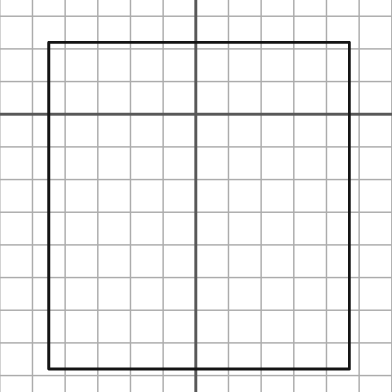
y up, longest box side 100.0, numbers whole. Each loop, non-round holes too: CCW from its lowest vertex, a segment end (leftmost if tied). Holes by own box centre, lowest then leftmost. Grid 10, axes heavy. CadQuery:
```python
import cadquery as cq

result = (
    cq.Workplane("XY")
    .moveTo(-45.0, -78.0)
    .lineTo(47.0, -78.0)
    .lineTo(47.0, 22.0)
    .lineTo(-45.0, 22.0)
    .close()
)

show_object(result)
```